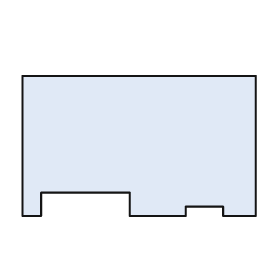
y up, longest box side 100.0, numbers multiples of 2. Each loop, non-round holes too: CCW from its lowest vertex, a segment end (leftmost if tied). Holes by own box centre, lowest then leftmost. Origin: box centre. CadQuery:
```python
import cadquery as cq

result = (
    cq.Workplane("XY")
    .moveTo(-50.0, -30.0)
    .lineTo(-42.0, -30.0)
    .lineTo(-42.0, -20.0)
    .lineTo(-4.0, -20.0)
    .lineTo(-4.0, -30.0)
    .lineTo(20.0, -30.0)
    .lineTo(20.0, -26.0)
    .lineTo(36.0, -26.0)
    .lineTo(36.0, -30.0)
    .lineTo(50.0, -30.0)
    .lineTo(50.0, 30.0)
    .lineTo(-50.0, 30.0)
    .close()
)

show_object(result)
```